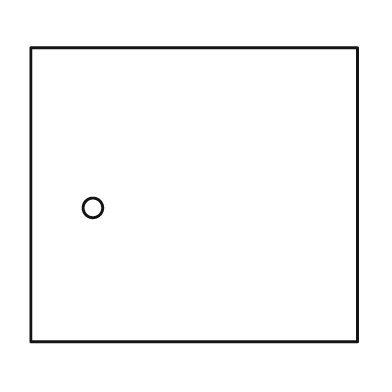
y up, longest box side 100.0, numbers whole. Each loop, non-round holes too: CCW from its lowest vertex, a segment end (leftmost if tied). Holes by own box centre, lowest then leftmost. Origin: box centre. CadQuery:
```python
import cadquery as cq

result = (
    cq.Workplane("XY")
    .moveTo(-50.0, -45.0)
    .lineTo(50.0, -45.0)
    .lineTo(50.0, 45.0)
    .lineTo(-50.0, 45.0)
    .close()
    .moveTo(-31.0, -4.0)
    .circle(3.0)
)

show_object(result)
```